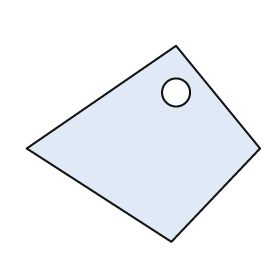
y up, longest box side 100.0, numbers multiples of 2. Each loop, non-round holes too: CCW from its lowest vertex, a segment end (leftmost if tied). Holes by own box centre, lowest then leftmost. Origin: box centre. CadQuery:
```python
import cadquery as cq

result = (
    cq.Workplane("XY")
    .moveTo(12.0, -42.0)
    .lineTo(50.0, -2.0)
    .lineTo(14.0, 42.0)
    .lineTo(-50.0, -2.0)
    .close()
    .moveTo(14.0, 22.0)
    .circle(6.0)
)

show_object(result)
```